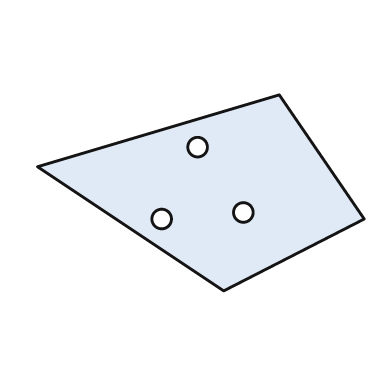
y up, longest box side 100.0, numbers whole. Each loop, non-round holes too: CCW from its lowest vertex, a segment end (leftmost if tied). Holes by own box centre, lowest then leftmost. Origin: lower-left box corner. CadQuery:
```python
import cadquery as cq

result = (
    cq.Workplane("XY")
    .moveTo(57.0, 0.0)
    .lineTo(100.0, 22.0)
    .lineTo(74.0, 60.0)
    .lineTo(0.0, 38.0)
    .close()
    .moveTo(38.0, 22.0)
    .circle(3.0)
    .moveTo(63.0, 24.0)
    .circle(3.0)
    .moveTo(49.0, 44.0)
    .circle(3.0)
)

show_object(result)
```